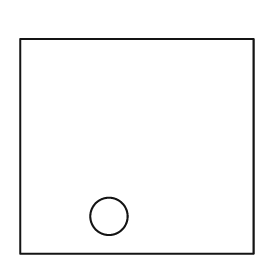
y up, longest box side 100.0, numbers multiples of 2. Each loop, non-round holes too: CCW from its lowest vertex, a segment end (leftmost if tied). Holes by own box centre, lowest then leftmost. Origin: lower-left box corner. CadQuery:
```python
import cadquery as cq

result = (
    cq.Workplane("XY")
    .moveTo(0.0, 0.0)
    .lineTo(100.0, 0.0)
    .lineTo(100.0, 92.0)
    .lineTo(0.0, 92.0)
    .close()
    .moveTo(38.0, 16.0)
    .circle(8.0)
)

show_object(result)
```